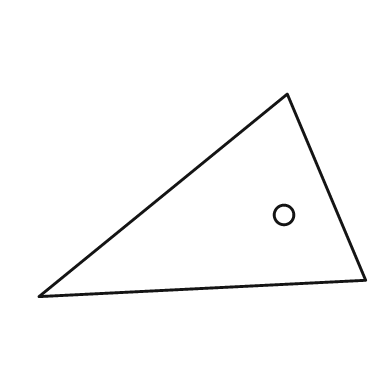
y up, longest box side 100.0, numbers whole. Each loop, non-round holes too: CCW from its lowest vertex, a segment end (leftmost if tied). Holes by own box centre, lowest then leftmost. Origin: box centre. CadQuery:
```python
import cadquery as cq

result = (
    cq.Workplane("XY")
    .moveTo(-50.0, -31.0)
    .lineTo(50.0, -26.0)
    .lineTo(26.0, 31.0)
    .close()
    .moveTo(25.0, -6.0)
    .circle(3.0)
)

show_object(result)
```